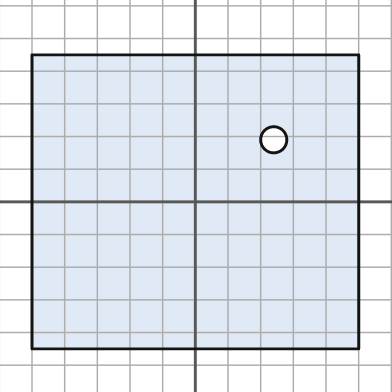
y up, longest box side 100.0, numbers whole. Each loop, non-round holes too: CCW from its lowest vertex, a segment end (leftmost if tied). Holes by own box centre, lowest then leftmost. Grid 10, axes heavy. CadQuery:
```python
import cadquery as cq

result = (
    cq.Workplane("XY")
    .moveTo(-50.0, -45.0)
    .lineTo(50.0, -45.0)
    .lineTo(50.0, 45.0)
    .lineTo(-50.0, 45.0)
    .close()
    .moveTo(24.0, 19.0)
    .circle(4.0)
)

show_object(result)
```